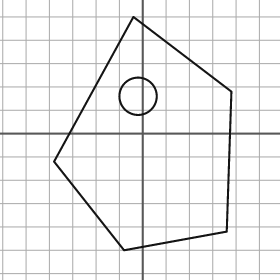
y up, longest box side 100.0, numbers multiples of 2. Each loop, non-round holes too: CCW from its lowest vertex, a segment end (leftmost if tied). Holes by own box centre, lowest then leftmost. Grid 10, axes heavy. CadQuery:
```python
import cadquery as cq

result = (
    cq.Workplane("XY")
    .moveTo(-8.0, -50.0)
    .lineTo(36.0, -42.0)
    .lineTo(38.0, 18.0)
    .lineTo(-4.0, 50.0)
    .lineTo(-38.0, -12.0)
    .close()
    .moveTo(-2.0, 16.0)
    .circle(8.0)
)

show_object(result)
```